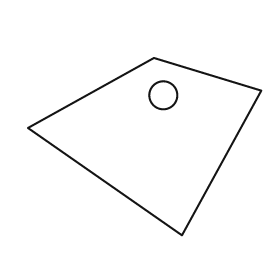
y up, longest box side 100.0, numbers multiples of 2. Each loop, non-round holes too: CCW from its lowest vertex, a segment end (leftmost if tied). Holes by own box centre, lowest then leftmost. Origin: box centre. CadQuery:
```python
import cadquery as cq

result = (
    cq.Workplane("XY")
    .moveTo(16.0, -38.0)
    .lineTo(50.0, 24.0)
    .lineTo(4.0, 38.0)
    .lineTo(-50.0, 8.0)
    .close()
    .moveTo(8.0, 22.0)
    .circle(6.0)
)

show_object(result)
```